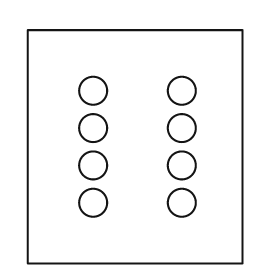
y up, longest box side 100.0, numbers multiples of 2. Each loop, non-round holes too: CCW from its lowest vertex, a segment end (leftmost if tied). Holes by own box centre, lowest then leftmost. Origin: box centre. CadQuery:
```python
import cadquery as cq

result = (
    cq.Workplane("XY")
    .moveTo(-46.0, -50.0)
    .lineTo(46.0, -50.0)
    .lineTo(46.0, 50.0)
    .lineTo(-46.0, 50.0)
    .close()
    .moveTo(-18.0, -24.0)
    .circle(6.0)
    .moveTo(20.0, -24.0)
    .circle(6.0)
    .moveTo(-18.0, -8.0)
    .circle(6.0)
    .moveTo(20.0, -8.0)
    .circle(6.0)
    .moveTo(-18.0, 8.0)
    .circle(6.0)
    .moveTo(20.0, 8.0)
    .circle(6.0)
    .moveTo(-18.0, 24.0)
    .circle(6.0)
    .moveTo(20.0, 24.0)
    .circle(6.0)
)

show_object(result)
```